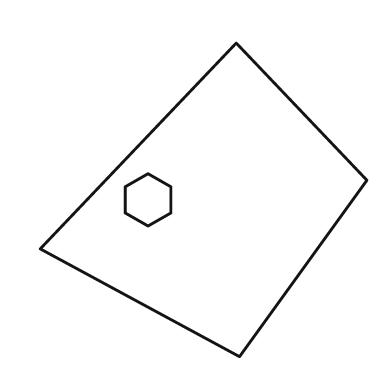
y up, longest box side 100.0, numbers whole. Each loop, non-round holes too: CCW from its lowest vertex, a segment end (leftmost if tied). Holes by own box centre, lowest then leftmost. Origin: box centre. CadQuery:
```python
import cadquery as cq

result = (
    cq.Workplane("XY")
    .moveTo(11.0, -48.0)
    .lineTo(50.0, 6.0)
    .lineTo(10.0, 48.0)
    .lineTo(-50.0, -15.0)
    .close()
    .moveTo(-17.0, -8.0)
    .lineTo(-10.0, -4.0)
    .lineTo(-10.0, 4.0)
    .lineTo(-17.0, 8.0)
    .lineTo(-24.0, 4.0)
    .lineTo(-24.0, -4.0)
    .close()
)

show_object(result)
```